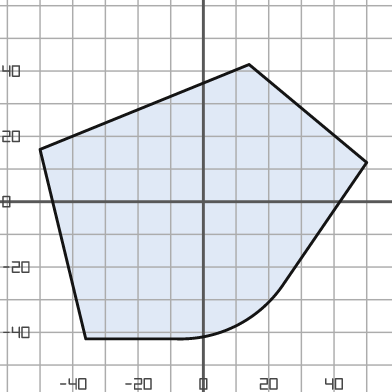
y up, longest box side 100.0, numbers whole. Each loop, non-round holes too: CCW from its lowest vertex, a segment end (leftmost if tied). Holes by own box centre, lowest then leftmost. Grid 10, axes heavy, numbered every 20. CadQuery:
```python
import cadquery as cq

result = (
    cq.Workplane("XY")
    .moveTo(-36.0, -42.0)
    .lineTo(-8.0, -42.0)
    .threePointArc((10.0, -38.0), (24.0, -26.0))
    .lineTo(50.0, 12.0)
    .lineTo(14.0, 42.0)
    .lineTo(-50.0, 16.0)
    .close()
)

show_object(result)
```